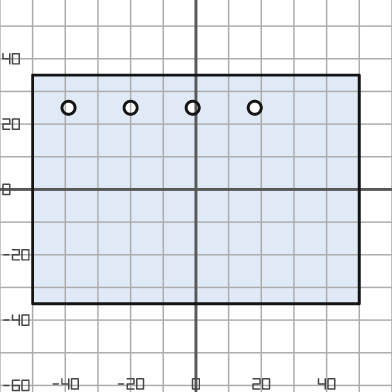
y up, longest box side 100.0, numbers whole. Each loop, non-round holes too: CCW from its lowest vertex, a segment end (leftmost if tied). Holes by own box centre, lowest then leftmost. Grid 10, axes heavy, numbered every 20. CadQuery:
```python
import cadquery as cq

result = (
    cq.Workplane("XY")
    .moveTo(-50.0, -35.0)
    .lineTo(50.0, -35.0)
    .lineTo(50.0, 35.0)
    .lineTo(-50.0, 35.0)
    .close()
    .moveTo(-39.0, 25.0)
    .circle(2.0)
    .moveTo(-20.0, 25.0)
    .circle(2.0)
    .moveTo(-1.0, 25.0)
    .circle(2.0)
    .moveTo(18.0, 25.0)
    .circle(2.0)
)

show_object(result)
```